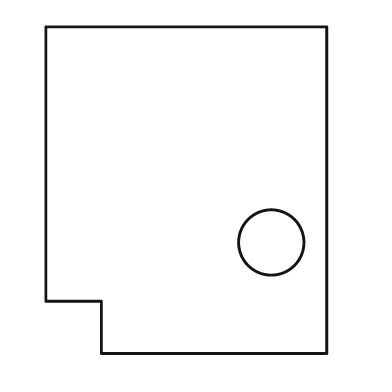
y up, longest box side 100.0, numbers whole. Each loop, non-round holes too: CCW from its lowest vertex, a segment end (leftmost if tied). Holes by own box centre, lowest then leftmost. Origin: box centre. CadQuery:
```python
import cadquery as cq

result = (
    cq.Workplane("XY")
    .moveTo(-26.0, -50.0)
    .lineTo(43.0, -50.0)
    .lineTo(43.0, 50.0)
    .lineTo(-43.0, 50.0)
    .lineTo(-43.0, -34.0)
    .lineTo(-26.0, -34.0)
    .close()
    .moveTo(26.0, -16.0)
    .circle(10.0)
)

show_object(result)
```